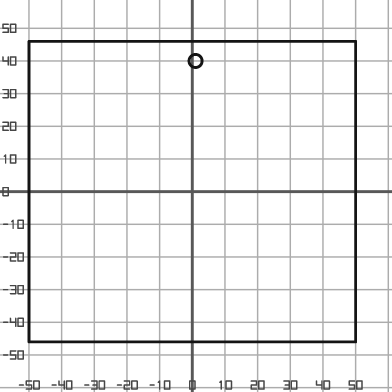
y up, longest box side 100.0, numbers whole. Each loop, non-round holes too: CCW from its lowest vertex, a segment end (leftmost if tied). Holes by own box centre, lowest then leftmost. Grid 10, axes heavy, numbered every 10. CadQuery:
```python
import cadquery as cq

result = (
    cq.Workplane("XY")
    .moveTo(-50.0, -46.0)
    .lineTo(50.0, -46.0)
    .lineTo(50.0, 46.0)
    .lineTo(-50.0, 46.0)
    .close()
    .moveTo(1.0, 40.0)
    .circle(2.0)
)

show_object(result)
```